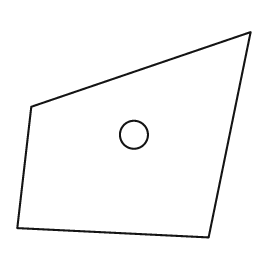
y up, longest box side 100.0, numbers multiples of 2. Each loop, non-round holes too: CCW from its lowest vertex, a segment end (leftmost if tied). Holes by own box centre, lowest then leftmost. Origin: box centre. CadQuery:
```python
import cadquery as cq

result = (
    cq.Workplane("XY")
    .moveTo(32.0, -44.0)
    .lineTo(50.0, 44.0)
    .lineTo(-44.0, 12.0)
    .lineTo(-50.0, -40.0)
    .close()
    .moveTo(0.0, 0.0)
    .circle(6.0)
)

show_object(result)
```